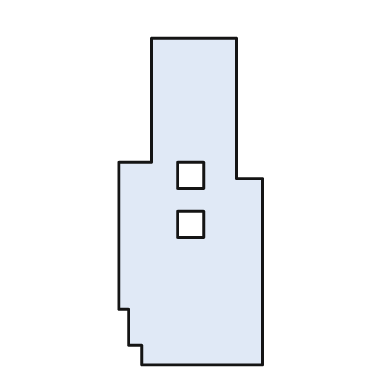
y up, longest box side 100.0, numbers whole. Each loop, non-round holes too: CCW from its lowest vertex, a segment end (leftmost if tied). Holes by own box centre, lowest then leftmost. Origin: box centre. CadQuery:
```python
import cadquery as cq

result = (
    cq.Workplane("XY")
    .moveTo(-15.0, -50.0)
    .lineTo(22.0, -50.0)
    .lineTo(22.0, 7.0)
    .lineTo(14.0, 7.0)
    .lineTo(14.0, 50.0)
    .lineTo(-12.0, 50.0)
    .lineTo(-12.0, 12.0)
    .lineTo(-22.0, 12.0)
    .lineTo(-22.0, -33.0)
    .lineTo(-19.0, -33.0)
    .lineTo(-19.0, -44.0)
    .lineTo(-15.0, -44.0)
    .close()
    .moveTo(-4.0, -11.0)
    .lineTo(4.0, -11.0)
    .lineTo(4.0, -3.0)
    .lineTo(-4.0, -3.0)
    .close()
    .moveTo(-4.0, 4.0)
    .lineTo(4.0, 4.0)
    .lineTo(4.0, 12.0)
    .lineTo(-4.0, 12.0)
    .close()
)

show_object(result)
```